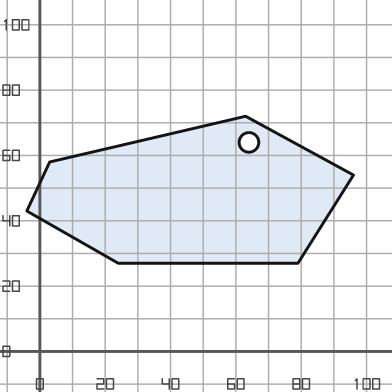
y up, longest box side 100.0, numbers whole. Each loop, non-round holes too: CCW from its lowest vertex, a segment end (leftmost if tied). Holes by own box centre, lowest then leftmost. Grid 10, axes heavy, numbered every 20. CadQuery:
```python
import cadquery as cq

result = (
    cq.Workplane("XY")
    .moveTo(24.0, 27.0)
    .lineTo(79.0, 27.0)
    .lineTo(96.0, 54.0)
    .lineTo(63.0, 72.0)
    .lineTo(3.0, 58.0)
    .lineTo(-4.0, 43.0)
    .close()
    .moveTo(64.0, 64.0)
    .circle(3.0)
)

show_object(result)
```